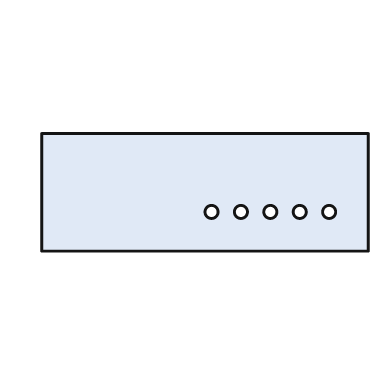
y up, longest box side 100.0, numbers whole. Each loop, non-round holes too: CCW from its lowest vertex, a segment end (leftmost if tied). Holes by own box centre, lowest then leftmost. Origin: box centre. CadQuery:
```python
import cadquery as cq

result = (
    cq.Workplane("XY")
    .moveTo(-50.0, -18.0)
    .lineTo(50.0, -18.0)
    .lineTo(50.0, 18.0)
    .lineTo(-50.0, 18.0)
    .close()
    .moveTo(2.0, -6.0)
    .circle(2.0)
    .moveTo(11.0, -6.0)
    .circle(2.0)
    .moveTo(20.0, -6.0)
    .circle(2.0)
    .moveTo(29.0, -6.0)
    .circle(2.0)
    .moveTo(38.0, -6.0)
    .circle(2.0)
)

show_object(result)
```